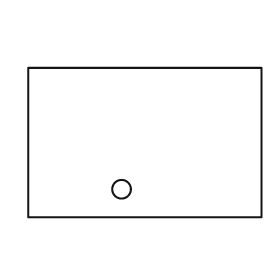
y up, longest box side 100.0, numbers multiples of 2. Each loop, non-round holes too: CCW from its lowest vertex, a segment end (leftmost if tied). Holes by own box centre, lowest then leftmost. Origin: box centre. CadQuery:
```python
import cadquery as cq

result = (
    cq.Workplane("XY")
    .moveTo(-50.0, -32.0)
    .lineTo(50.0, -32.0)
    .lineTo(50.0, 32.0)
    .lineTo(-50.0, 32.0)
    .close()
    .moveTo(-10.0, -20.0)
    .circle(4.0)
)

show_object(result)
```